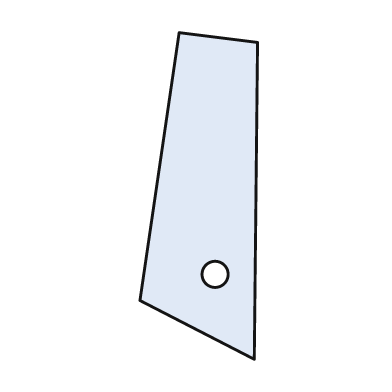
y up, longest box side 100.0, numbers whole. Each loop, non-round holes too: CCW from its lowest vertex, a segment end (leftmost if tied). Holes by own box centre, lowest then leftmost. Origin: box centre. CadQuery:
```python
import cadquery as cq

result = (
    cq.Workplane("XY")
    .moveTo(17.0, -50.0)
    .lineTo(18.0, 47.0)
    .lineTo(-6.0, 50.0)
    .lineTo(-18.0, -32.0)
    .close()
    .moveTo(5.0, -24.0)
    .circle(4.0)
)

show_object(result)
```